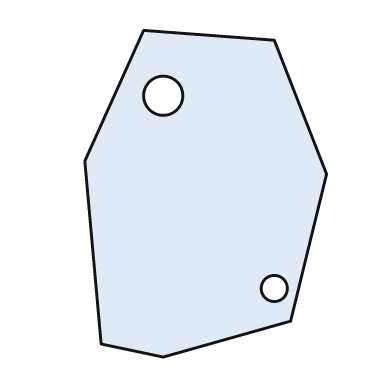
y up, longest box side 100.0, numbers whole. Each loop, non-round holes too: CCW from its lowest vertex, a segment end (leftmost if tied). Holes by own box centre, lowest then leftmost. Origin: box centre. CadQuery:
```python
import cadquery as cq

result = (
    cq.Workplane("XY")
    .moveTo(-13.0, -50.0)
    .lineTo(26.0, -39.0)
    .lineTo(37.0, 6.0)
    .lineTo(21.0, 47.0)
    .lineTo(-19.0, 50.0)
    .lineTo(-37.0, 10.0)
    .lineTo(-32.0, -46.0)
    .close()
    .moveTo(21.0, -29.0)
    .circle(4.0)
    .moveTo(-13.0, 30.0)
    .circle(6.0)
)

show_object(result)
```